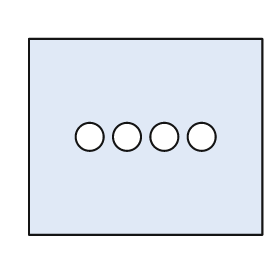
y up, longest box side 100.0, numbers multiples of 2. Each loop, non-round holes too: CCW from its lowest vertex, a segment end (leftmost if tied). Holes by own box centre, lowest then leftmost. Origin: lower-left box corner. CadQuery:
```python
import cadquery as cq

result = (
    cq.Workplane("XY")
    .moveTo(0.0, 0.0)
    .lineTo(100.0, 0.0)
    .lineTo(100.0, 84.0)
    .lineTo(0.0, 84.0)
    .close()
    .moveTo(26.0, 42.0)
    .circle(6.0)
    .moveTo(42.0, 42.0)
    .circle(6.0)
    .moveTo(58.0, 42.0)
    .circle(6.0)
    .moveTo(74.0, 42.0)
    .circle(6.0)
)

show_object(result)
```